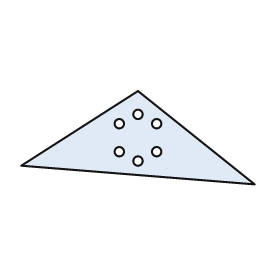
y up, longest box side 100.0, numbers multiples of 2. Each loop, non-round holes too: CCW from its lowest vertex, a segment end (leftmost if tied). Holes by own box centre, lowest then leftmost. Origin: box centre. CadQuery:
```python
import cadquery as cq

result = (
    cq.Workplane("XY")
    .moveTo(50.0, -20.0)
    .lineTo(0.0, 20.0)
    .lineTo(-50.0, -12.0)
    .close()
    .moveTo(0.0, -10.0)
    .circle(2.0)
    .moveTo(-8.0, -6.0)
    .circle(2.0)
    .moveTo(8.0, -6.0)
    .circle(2.0)
    .moveTo(-8.0, 6.0)
    .circle(2.0)
    .moveTo(8.0, 6.0)
    .circle(2.0)
    .moveTo(0.0, 10.0)
    .circle(2.0)
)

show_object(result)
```